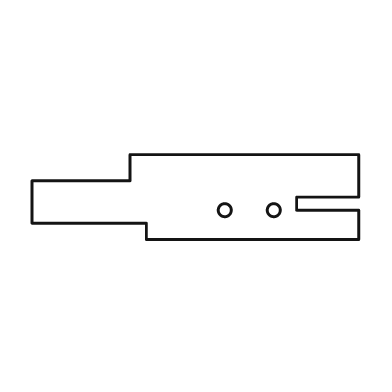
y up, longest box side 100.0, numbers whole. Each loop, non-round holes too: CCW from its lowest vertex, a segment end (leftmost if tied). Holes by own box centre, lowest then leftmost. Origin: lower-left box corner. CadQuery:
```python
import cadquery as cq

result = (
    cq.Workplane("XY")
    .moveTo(35.0, 0.0)
    .lineTo(100.0, 0.0)
    .lineTo(100.0, 9.0)
    .lineTo(81.0, 9.0)
    .lineTo(81.0, 13.0)
    .lineTo(100.0, 13.0)
    .lineTo(100.0, 26.0)
    .lineTo(30.0, 26.0)
    .lineTo(30.0, 18.0)
    .lineTo(0.0, 18.0)
    .lineTo(0.0, 5.0)
    .lineTo(35.0, 5.0)
    .close()
    .moveTo(59.0, 9.0)
    .circle(2.0)
    .moveTo(74.0, 9.0)
    .circle(2.0)
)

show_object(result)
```